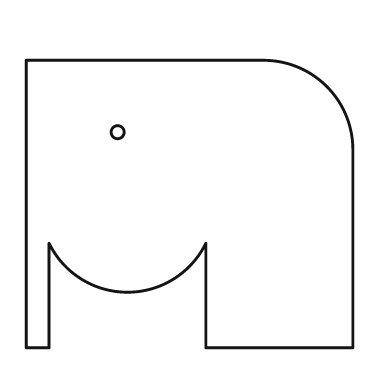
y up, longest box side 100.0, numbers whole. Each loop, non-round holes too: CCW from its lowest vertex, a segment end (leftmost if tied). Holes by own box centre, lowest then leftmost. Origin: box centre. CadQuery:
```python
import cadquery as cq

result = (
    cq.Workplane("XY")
    .moveTo(-50.0, -44.0)
    .lineTo(-43.0, -44.0)
    .lineTo(-43.0, -12.0)
    .threePointArc((-19.0, -27.0), (5.0, -12.0))
    .lineTo(5.0, -44.0)
    .lineTo(50.0, -44.0)
    .lineTo(50.0, 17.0)
    .threePointArc((42.0, 36.0), (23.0, 44.0))
    .lineTo(-50.0, 44.0)
    .close()
    .moveTo(-22.0, 22.0)
    .circle(2.0)
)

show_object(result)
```